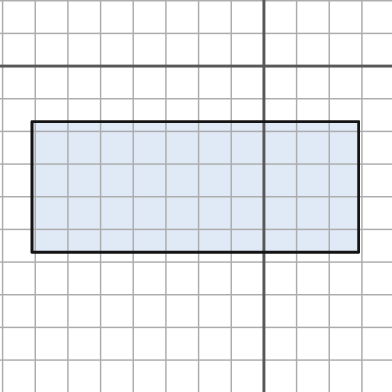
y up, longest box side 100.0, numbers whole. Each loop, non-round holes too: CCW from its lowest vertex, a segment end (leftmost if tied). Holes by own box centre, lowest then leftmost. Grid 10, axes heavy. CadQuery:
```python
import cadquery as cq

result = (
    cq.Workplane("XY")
    .moveTo(-71.0, -57.0)
    .lineTo(29.0, -57.0)
    .lineTo(29.0, -17.0)
    .lineTo(-71.0, -17.0)
    .close()
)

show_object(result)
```